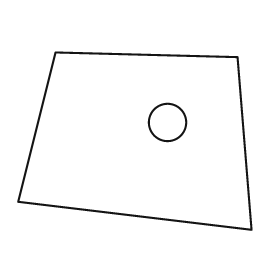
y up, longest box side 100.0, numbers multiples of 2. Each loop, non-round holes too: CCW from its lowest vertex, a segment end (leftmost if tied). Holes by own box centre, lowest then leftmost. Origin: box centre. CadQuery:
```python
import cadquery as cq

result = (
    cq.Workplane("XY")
    .moveTo(50.0, -38.0)
    .lineTo(44.0, 36.0)
    .lineTo(-34.0, 38.0)
    .lineTo(-50.0, -26.0)
    .close()
    .moveTo(14.0, 8.0)
    .circle(8.0)
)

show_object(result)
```